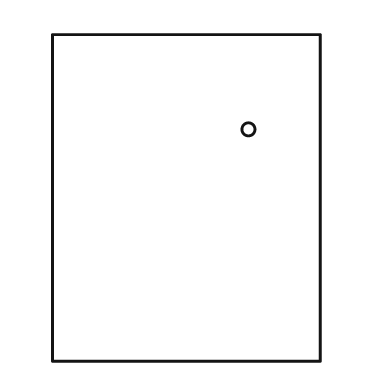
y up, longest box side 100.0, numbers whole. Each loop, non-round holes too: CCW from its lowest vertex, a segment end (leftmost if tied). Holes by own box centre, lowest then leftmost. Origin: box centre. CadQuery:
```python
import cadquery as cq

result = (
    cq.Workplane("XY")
    .moveTo(-41.0, -50.0)
    .lineTo(41.0, -50.0)
    .lineTo(41.0, 50.0)
    .lineTo(-41.0, 50.0)
    .close()
    .moveTo(19.0, 21.0)
    .circle(2.0)
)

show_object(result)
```